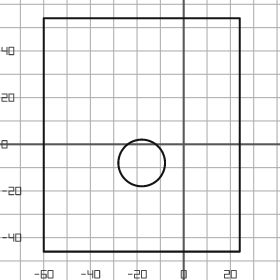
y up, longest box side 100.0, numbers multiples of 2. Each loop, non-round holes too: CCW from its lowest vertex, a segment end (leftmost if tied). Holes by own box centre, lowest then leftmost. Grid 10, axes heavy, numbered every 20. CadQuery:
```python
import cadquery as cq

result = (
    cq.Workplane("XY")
    .moveTo(-60.0, -46.0)
    .lineTo(24.0, -46.0)
    .lineTo(24.0, 54.0)
    .lineTo(-60.0, 54.0)
    .close()
    .moveTo(-18.0, -8.0)
    .circle(10.0)
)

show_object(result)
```